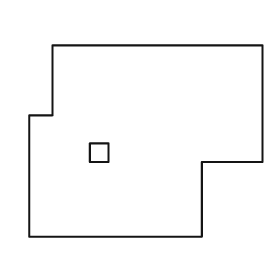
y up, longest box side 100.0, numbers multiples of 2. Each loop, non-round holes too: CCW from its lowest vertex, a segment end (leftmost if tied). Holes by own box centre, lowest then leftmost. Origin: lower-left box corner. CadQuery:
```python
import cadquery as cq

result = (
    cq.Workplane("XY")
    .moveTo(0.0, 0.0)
    .lineTo(74.0, 0.0)
    .lineTo(74.0, 32.0)
    .lineTo(100.0, 32.0)
    .lineTo(100.0, 82.0)
    .lineTo(10.0, 82.0)
    .lineTo(10.0, 52.0)
    .lineTo(0.0, 52.0)
    .close()
    .moveTo(26.0, 32.0)
    .lineTo(34.0, 32.0)
    .lineTo(34.0, 40.0)
    .lineTo(26.0, 40.0)
    .close()
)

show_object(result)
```